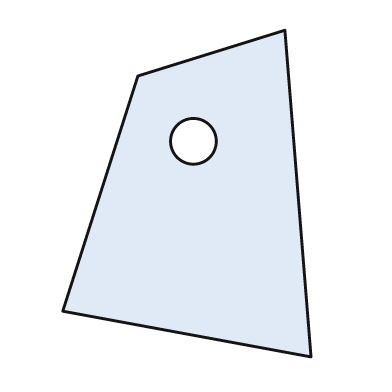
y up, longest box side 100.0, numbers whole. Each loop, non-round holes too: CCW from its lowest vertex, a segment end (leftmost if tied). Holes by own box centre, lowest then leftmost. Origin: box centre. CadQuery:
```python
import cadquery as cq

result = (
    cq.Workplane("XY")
    .moveTo(38.0, -50.0)
    .lineTo(30.0, 50.0)
    .lineTo(-15.0, 36.0)
    .lineTo(-38.0, -36.0)
    .close()
    .moveTo(2.0, 16.0)
    .circle(7.0)
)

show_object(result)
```